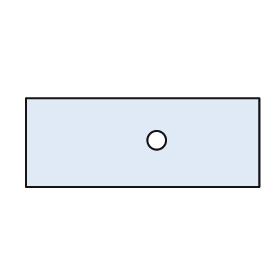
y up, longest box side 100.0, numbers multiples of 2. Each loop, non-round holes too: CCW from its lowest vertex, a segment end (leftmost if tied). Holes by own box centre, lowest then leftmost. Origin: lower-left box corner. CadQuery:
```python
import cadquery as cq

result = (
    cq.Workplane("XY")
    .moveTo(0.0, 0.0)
    .lineTo(100.0, 0.0)
    .lineTo(100.0, 38.0)
    .lineTo(0.0, 38.0)
    .close()
    .moveTo(56.0, 20.0)
    .circle(4.0)
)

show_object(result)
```